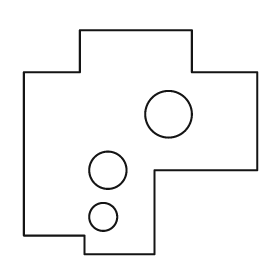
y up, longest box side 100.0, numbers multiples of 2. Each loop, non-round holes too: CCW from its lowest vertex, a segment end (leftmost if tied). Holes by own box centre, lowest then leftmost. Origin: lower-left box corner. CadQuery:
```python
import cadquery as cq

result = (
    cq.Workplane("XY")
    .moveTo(26.0, 0.0)
    .lineTo(56.0, 0.0)
    .lineTo(56.0, 36.0)
    .lineTo(100.0, 36.0)
    .lineTo(100.0, 78.0)
    .lineTo(72.0, 78.0)
    .lineTo(72.0, 96.0)
    .lineTo(24.0, 96.0)
    .lineTo(24.0, 78.0)
    .lineTo(0.0, 78.0)
    .lineTo(0.0, 8.0)
    .lineTo(26.0, 8.0)
    .close()
    .moveTo(34.0, 16.0)
    .circle(6.0)
    .moveTo(36.0, 36.0)
    .circle(8.0)
    .moveTo(62.0, 60.0)
    .circle(10.0)
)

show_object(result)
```